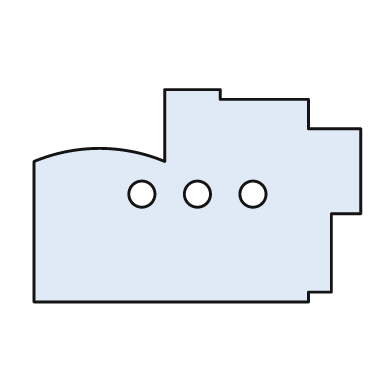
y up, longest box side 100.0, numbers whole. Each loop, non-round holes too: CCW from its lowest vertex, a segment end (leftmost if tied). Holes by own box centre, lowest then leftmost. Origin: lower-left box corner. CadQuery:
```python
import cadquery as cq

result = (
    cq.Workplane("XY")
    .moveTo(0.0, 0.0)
    .lineTo(84.0, 0.0)
    .lineTo(84.0, 3.0)
    .lineTo(91.0, 3.0)
    .lineTo(91.0, 27.0)
    .lineTo(100.0, 27.0)
    .lineTo(100.0, 53.0)
    .lineTo(84.0, 53.0)
    .lineTo(84.0, 62.0)
    .lineTo(57.0, 62.0)
    .lineTo(57.0, 65.0)
    .lineTo(40.0, 65.0)
    .lineTo(40.0, 43.0)
    .threePointArc((20.0, 47.0), (0.0, 43.0))
    .close()
    .moveTo(33.0, 33.0)
    .circle(4.0)
    .moveTo(50.0, 33.0)
    .circle(4.0)
    .moveTo(67.0, 33.0)
    .circle(4.0)
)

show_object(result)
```